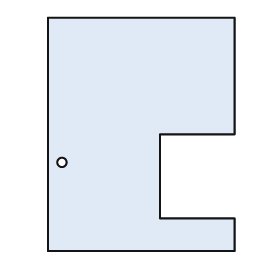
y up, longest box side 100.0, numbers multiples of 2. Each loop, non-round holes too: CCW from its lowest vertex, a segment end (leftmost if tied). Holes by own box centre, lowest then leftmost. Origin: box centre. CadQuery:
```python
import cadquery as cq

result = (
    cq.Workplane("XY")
    .moveTo(-40.0, -50.0)
    .lineTo(40.0, -50.0)
    .lineTo(40.0, -36.0)
    .lineTo(8.0, -36.0)
    .lineTo(8.0, 0.0)
    .lineTo(40.0, 0.0)
    .lineTo(40.0, 50.0)
    .lineTo(-40.0, 50.0)
    .close()
    .moveTo(-34.0, -12.0)
    .circle(2.0)
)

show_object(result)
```